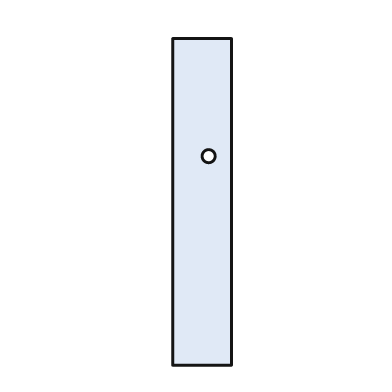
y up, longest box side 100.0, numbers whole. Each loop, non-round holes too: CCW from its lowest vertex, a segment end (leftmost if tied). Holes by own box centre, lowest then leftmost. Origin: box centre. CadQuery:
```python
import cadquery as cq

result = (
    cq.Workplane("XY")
    .moveTo(-9.0, -50.0)
    .lineTo(9.0, -50.0)
    .lineTo(9.0, 50.0)
    .lineTo(-9.0, 50.0)
    .close()
    .moveTo(2.0, 14.0)
    .circle(2.0)
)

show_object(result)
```